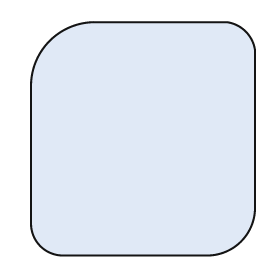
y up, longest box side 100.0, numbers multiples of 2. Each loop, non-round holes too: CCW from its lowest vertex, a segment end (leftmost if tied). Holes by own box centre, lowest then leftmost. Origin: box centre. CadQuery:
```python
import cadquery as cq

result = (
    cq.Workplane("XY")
    .moveTo(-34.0, -50.0)
    .lineTo(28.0, -50.0)
    .threePointArc((42.0, -44.0), (48.0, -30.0))
    .lineTo(48.0, 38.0)
    .threePointArc((44.0, 46.0), (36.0, 50.0))
    .lineTo(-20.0, 50.0)
    .threePointArc((-40.0, 42.0), (-48.0, 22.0))
    .lineTo(-48.0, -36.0)
    .threePointArc((-44.0, -46.0), (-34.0, -50.0))
    .close()
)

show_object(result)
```